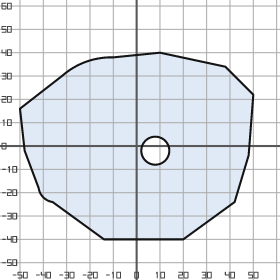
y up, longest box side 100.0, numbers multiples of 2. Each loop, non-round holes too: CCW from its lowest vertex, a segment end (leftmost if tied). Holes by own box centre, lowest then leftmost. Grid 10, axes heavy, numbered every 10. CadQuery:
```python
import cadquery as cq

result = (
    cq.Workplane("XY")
    .moveTo(-14.0, -40.0)
    .lineTo(20.0, -40.0)
    .lineTo(42.0, -24.0)
    .lineTo(48.0, -4.0)
    .lineTo(50.0, 22.0)
    .lineTo(38.0, 34.0)
    .lineTo(10.0, 40.0)
    .lineTo(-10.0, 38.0)
    .threePointArc((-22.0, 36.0), (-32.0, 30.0))
    .lineTo(-50.0, 16.0)
    .lineTo(-48.0, -2.0)
    .lineTo(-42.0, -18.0)
    .threePointArc((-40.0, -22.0), (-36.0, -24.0))
    .close()
    .moveTo(8.0, -2.0)
    .circle(6.0)
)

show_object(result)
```